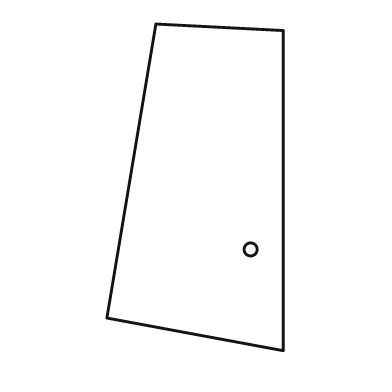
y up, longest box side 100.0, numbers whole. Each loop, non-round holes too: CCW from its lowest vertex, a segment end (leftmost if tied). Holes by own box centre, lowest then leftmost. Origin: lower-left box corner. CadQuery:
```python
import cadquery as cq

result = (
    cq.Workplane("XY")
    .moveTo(54.0, 0.0)
    .lineTo(54.0, 98.0)
    .lineTo(15.0, 100.0)
    .lineTo(0.0, 10.0)
    .close()
    .moveTo(44.0, 31.0)
    .circle(2.0)
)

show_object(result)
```